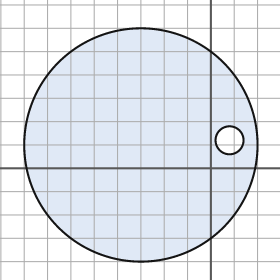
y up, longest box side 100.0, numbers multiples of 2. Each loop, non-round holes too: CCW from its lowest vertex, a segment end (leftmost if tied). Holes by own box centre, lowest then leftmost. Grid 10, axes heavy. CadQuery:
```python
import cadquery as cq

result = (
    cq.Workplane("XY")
    .moveTo(-30.0, 10.0)
    .circle(50.0)
    .moveTo(8.0, 12.0)
    .circle(6.0)
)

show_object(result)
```